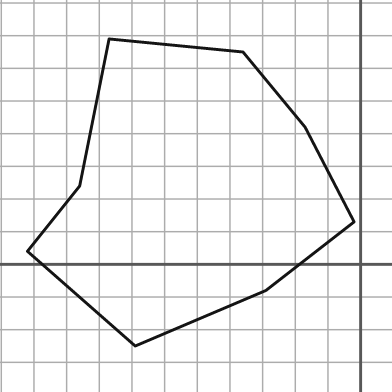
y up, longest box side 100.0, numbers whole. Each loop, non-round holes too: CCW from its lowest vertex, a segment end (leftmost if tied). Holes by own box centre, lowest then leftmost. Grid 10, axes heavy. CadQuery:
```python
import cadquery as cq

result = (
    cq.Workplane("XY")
    .moveTo(-69.0, -25.0)
    .lineTo(-29.0, -8.0)
    .lineTo(-2.0, 13.0)
    .lineTo(-17.0, 42.0)
    .lineTo(-36.0, 65.0)
    .lineTo(-77.0, 69.0)
    .lineTo(-86.0, 24.0)
    .lineTo(-102.0, 4.0)
    .close()
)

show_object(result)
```